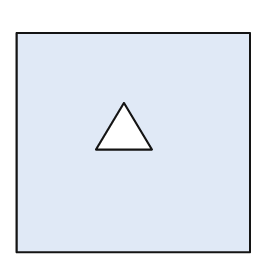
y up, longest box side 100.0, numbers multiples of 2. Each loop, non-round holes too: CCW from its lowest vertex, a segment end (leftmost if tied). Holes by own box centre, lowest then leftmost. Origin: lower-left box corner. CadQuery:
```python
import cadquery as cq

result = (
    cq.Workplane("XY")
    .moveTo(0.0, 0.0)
    .lineTo(100.0, 0.0)
    .lineTo(100.0, 94.0)
    .lineTo(0.0, 94.0)
    .close()
    .moveTo(34.0, 44.0)
    .lineTo(58.0, 44.0)
    .lineTo(46.0, 64.0)
    .close()
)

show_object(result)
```